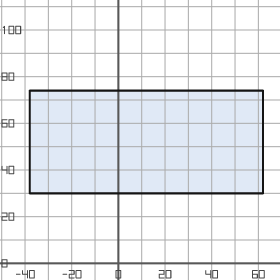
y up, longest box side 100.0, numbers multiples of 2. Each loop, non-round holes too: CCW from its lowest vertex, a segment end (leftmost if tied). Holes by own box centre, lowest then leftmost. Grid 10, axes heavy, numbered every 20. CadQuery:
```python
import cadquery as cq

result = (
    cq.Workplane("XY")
    .moveTo(-38.0, 30.0)
    .lineTo(62.0, 30.0)
    .lineTo(62.0, 74.0)
    .lineTo(-38.0, 74.0)
    .close()
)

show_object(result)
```